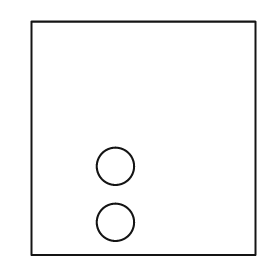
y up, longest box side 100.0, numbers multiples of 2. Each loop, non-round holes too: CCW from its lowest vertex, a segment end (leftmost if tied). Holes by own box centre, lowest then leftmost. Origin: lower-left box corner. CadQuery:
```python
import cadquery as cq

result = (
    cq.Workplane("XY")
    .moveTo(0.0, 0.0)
    .lineTo(96.0, 0.0)
    .lineTo(96.0, 100.0)
    .lineTo(0.0, 100.0)
    .close()
    .moveTo(36.0, 14.0)
    .circle(8.0)
    .moveTo(36.0, 38.0)
    .circle(8.0)
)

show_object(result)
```